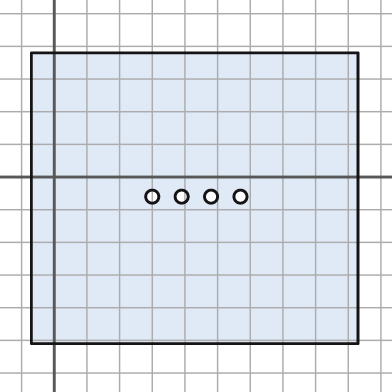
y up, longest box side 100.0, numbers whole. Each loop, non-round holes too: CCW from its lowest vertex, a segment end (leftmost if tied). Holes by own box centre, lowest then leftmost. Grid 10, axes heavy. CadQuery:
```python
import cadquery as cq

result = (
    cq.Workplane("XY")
    .moveTo(-7.0, -51.0)
    .lineTo(93.0, -51.0)
    .lineTo(93.0, 38.0)
    .lineTo(-7.0, 38.0)
    .close()
    .moveTo(30.0, -6.0)
    .circle(2.0)
    .moveTo(39.0, -6.0)
    .circle(2.0)
    .moveTo(48.0, -6.0)
    .circle(2.0)
    .moveTo(57.0, -6.0)
    .circle(2.0)
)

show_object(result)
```